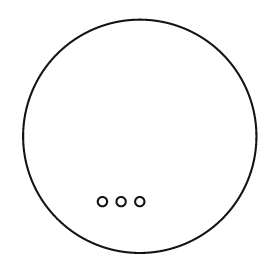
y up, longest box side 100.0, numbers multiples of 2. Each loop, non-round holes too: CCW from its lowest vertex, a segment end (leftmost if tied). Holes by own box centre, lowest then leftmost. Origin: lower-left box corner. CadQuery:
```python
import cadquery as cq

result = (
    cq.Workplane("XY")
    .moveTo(50.0, 50.0)
    .circle(50.0)
    .moveTo(34.0, 22.0)
    .circle(2.0)
    .moveTo(42.0, 22.0)
    .circle(2.0)
    .moveTo(50.0, 22.0)
    .circle(2.0)
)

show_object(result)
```